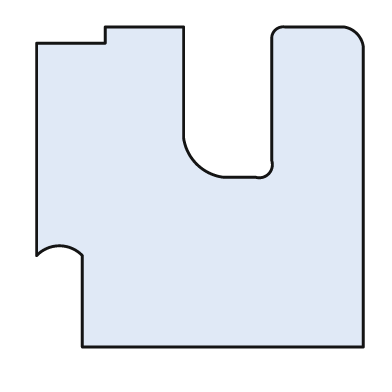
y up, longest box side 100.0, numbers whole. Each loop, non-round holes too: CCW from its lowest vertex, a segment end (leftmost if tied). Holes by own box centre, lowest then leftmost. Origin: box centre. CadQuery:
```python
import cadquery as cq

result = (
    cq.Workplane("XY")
    .moveTo(-36.0, -49.0)
    .lineTo(50.0, -49.0)
    .lineTo(50.0, 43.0)
    .threePointArc((48.0, 47.0), (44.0, 49.0))
    .lineTo(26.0, 49.0)
    .threePointArc((23.0, 48.0), (22.0, 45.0))
    .lineTo(22.0, 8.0)
    .threePointArc((21.0, 4.0), (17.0, 3.0))
    .lineTo(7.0, 3.0)
    .threePointArc((-1.0, 7.0), (-5.0, 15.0))
    .lineTo(-5.0, 49.0)
    .lineTo(-29.0, 49.0)
    .lineTo(-29.0, 44.0)
    .lineTo(-50.0, 44.0)
    .lineTo(-50.0, -21.0)
    .threePointArc((-43.0, -18.0), (-36.0, -21.0))
    .close()
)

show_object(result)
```